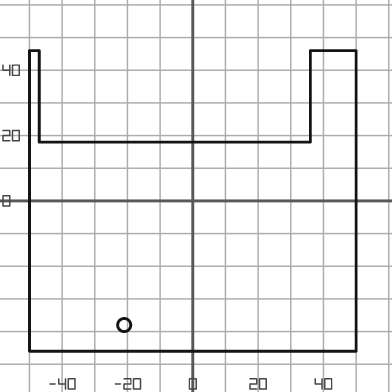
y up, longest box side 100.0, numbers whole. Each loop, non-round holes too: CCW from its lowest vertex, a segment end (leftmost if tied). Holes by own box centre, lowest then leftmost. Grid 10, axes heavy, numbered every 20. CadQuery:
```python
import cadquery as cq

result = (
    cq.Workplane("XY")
    .moveTo(-50.0, -46.0)
    .lineTo(50.0, -46.0)
    .lineTo(50.0, 46.0)
    .lineTo(36.0, 46.0)
    .lineTo(36.0, 18.0)
    .lineTo(-47.0, 18.0)
    .lineTo(-47.0, 46.0)
    .lineTo(-50.0, 46.0)
    .close()
    .moveTo(-21.0, -38.0)
    .circle(2.0)
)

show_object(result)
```